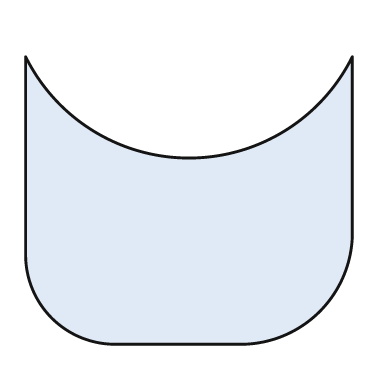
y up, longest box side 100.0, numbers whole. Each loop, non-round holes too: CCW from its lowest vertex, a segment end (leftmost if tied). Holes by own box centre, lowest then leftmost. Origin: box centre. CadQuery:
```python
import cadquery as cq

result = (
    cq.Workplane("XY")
    .moveTo(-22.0, -44.0)
    .lineTo(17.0, -44.0)
    .threePointArc((40.0, -34.0), (50.0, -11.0))
    .lineTo(50.0, 44.0)
    .threePointArc((0.0, 13.0), (-50.0, 44.0))
    .lineTo(-50.0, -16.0)
    .threePointArc((-42.0, -36.0), (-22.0, -44.0))
    .close()
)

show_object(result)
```